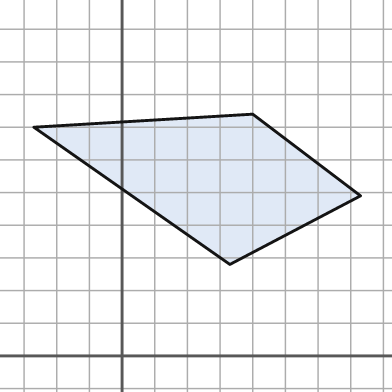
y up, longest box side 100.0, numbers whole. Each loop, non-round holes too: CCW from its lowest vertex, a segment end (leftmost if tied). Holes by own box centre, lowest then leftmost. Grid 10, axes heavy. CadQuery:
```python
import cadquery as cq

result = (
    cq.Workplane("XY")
    .moveTo(33.0, 28.0)
    .lineTo(73.0, 49.0)
    .lineTo(40.0, 74.0)
    .lineTo(-27.0, 70.0)
    .close()
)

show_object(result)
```